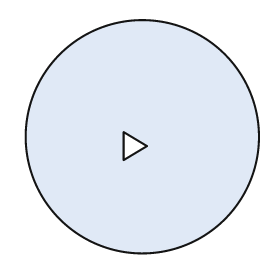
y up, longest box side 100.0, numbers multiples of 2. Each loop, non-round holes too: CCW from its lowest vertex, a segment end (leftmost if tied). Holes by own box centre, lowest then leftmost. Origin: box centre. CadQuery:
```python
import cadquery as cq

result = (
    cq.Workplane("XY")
    .moveTo(0.0, 0.0)
    .circle(50.0)
    .moveTo(-8.0, -10.0)
    .lineTo(2.0, -4.0)
    .lineTo(-8.0, 2.0)
    .close()
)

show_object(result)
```